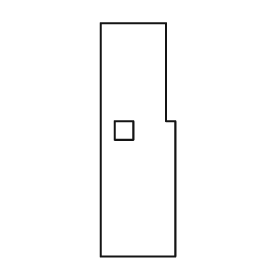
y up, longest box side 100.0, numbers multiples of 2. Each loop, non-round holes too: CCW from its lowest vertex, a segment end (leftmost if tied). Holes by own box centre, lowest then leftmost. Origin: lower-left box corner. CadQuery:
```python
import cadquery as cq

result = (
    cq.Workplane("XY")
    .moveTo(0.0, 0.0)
    .lineTo(32.0, 0.0)
    .lineTo(32.0, 58.0)
    .lineTo(28.0, 58.0)
    .lineTo(28.0, 100.0)
    .lineTo(0.0, 100.0)
    .close()
    .moveTo(6.0, 50.0)
    .lineTo(14.0, 50.0)
    .lineTo(14.0, 58.0)
    .lineTo(6.0, 58.0)
    .close()
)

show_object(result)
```